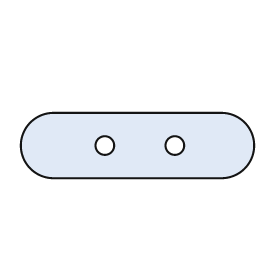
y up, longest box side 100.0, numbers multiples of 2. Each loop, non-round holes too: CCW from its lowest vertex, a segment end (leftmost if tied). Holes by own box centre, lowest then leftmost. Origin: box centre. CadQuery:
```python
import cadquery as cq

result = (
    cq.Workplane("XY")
    .moveTo(-36.0, -14.0)
    .lineTo(36.0, -14.0)
    .threePointArc((50.0, 0.0), (36.0, 14.0))
    .lineTo(-36.0, 14.0)
    .threePointArc((-50.0, 0.0), (-36.0, -14.0))
    .close()
    .moveTo(-14.0, 0.0)
    .circle(4.0)
    .moveTo(16.0, 0.0)
    .circle(4.0)
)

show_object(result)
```